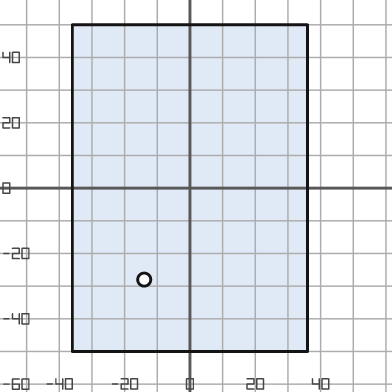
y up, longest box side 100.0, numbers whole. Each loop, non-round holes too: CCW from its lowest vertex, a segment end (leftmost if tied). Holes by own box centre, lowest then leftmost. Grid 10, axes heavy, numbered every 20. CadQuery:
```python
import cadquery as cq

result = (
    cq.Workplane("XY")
    .moveTo(-36.0, -50.0)
    .lineTo(36.0, -50.0)
    .lineTo(36.0, 50.0)
    .lineTo(-36.0, 50.0)
    .close()
    .moveTo(-14.0, -28.0)
    .circle(2.0)
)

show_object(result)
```